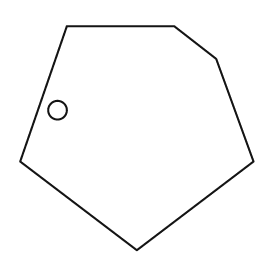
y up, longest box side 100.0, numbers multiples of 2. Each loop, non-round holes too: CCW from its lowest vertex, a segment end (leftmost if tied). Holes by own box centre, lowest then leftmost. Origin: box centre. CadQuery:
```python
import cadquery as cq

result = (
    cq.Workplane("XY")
    .moveTo(0.0, -48.0)
    .lineTo(50.0, -10.0)
    .lineTo(34.0, 34.0)
    .lineTo(16.0, 48.0)
    .lineTo(-30.0, 48.0)
    .lineTo(-50.0, -10.0)
    .close()
    .moveTo(-34.0, 12.0)
    .circle(4.0)
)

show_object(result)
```